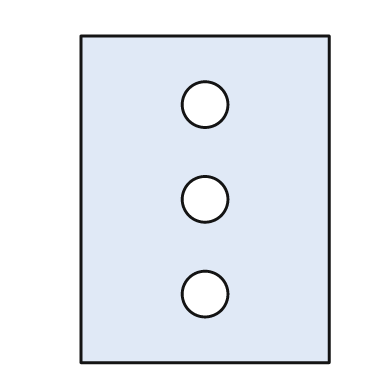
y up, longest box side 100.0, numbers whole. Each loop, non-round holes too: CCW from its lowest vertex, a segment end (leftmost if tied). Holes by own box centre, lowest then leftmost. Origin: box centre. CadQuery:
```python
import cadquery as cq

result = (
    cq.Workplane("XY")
    .moveTo(-38.0, -50.0)
    .lineTo(38.0, -50.0)
    .lineTo(38.0, 50.0)
    .lineTo(-38.0, 50.0)
    .close()
    .moveTo(0.0, -29.0)
    .circle(7.0)
    .moveTo(0.0, 0.0)
    .circle(7.0)
    .moveTo(0.0, 29.0)
    .circle(7.0)
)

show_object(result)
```